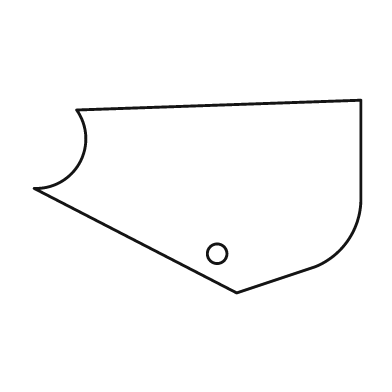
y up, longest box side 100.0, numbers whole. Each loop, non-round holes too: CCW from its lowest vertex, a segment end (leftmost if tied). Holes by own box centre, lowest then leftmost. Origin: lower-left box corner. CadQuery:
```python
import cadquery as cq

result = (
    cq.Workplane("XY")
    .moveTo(62.0, 0.0)
    .lineTo(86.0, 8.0)
    .threePointArc((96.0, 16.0), (100.0, 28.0))
    .lineTo(100.0, 59.0)
    .lineTo(13.0, 56.0)
    .threePointArc((14.0, 40.0), (0.0, 32.0))
    .close()
    .moveTo(56.0, 12.0)
    .circle(3.0)
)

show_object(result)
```